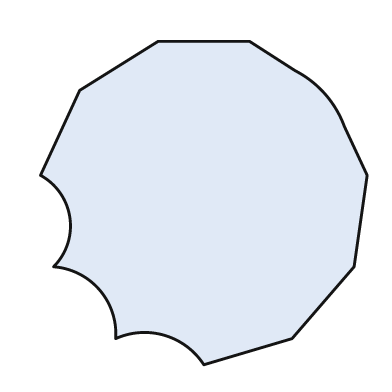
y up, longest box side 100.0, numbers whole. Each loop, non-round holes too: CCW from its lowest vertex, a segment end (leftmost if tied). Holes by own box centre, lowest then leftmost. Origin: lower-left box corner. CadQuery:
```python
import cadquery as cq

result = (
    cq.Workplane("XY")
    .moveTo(50.0, 0.0)
    .lineTo(77.0, 8.0)
    .lineTo(96.0, 30.0)
    .lineTo(100.0, 58.0)
    .lineTo(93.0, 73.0)
    .threePointArc((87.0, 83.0), (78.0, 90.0))
    .lineTo(64.0, 99.0)
    .lineTo(36.0, 99.0)
    .lineTo(12.0, 84.0)
    .lineTo(0.0, 58.0)
    .threePointArc((9.0, 45.0), (4.0, 30.0))
    .threePointArc((18.0, 23.0), (23.0, 8.0))
    .threePointArc((38.0, 9.0), (50.0, 0.0))
    .close()
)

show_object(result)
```